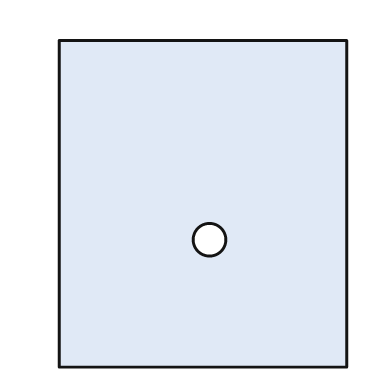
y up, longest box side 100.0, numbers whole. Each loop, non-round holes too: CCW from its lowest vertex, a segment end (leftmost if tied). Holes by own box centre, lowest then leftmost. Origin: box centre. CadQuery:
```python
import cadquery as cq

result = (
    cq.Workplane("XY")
    .moveTo(-44.0, -50.0)
    .lineTo(44.0, -50.0)
    .lineTo(44.0, 50.0)
    .lineTo(-44.0, 50.0)
    .close()
    .moveTo(2.0, -11.0)
    .circle(5.0)
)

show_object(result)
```